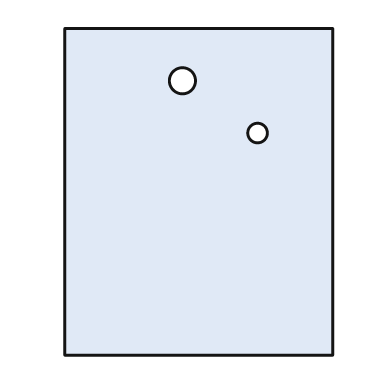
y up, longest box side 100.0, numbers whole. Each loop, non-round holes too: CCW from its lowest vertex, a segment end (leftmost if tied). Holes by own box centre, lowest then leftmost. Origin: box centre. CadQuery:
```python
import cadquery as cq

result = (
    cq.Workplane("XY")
    .moveTo(-41.0, -50.0)
    .lineTo(41.0, -50.0)
    .lineTo(41.0, 50.0)
    .lineTo(-41.0, 50.0)
    .close()
    .moveTo(18.0, 18.0)
    .circle(3.0)
    .moveTo(-5.0, 34.0)
    .circle(4.0)
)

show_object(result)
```